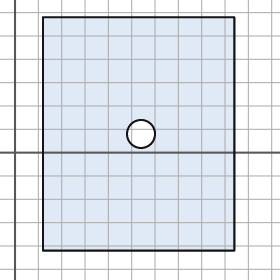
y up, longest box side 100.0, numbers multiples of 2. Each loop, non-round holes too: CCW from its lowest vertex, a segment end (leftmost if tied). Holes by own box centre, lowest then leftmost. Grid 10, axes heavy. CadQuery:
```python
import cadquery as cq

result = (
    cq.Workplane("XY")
    .moveTo(12.0, -42.0)
    .lineTo(94.0, -42.0)
    .lineTo(94.0, 58.0)
    .lineTo(12.0, 58.0)
    .close()
    .moveTo(54.0, 8.0)
    .circle(6.0)
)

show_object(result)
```